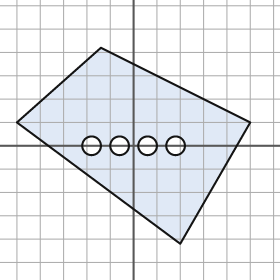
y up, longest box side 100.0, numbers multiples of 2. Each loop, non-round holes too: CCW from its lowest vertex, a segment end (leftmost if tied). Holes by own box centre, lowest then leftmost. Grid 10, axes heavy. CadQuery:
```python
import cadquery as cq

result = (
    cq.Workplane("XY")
    .moveTo(20.0, -42.0)
    .lineTo(50.0, 10.0)
    .lineTo(-14.0, 42.0)
    .lineTo(-50.0, 10.0)
    .close()
    .moveTo(-18.0, 0.0)
    .circle(4.0)
    .moveTo(-6.0, 0.0)
    .circle(4.0)
    .moveTo(6.0, 0.0)
    .circle(4.0)
    .moveTo(18.0, 0.0)
    .circle(4.0)
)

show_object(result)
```